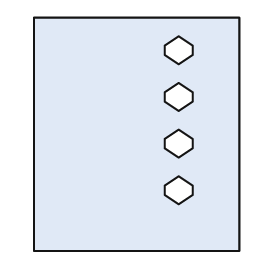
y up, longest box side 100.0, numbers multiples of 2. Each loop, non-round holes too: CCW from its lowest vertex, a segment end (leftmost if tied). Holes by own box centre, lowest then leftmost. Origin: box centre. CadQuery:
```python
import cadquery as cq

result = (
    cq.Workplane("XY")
    .moveTo(-44.0, -50.0)
    .lineTo(44.0, -50.0)
    .lineTo(44.0, 50.0)
    .lineTo(-44.0, 50.0)
    .close()
    .moveTo(18.0, -30.0)
    .lineTo(24.0, -26.0)
    .lineTo(24.0, -22.0)
    .lineTo(18.0, -18.0)
    .lineTo(12.0, -22.0)
    .lineTo(12.0, -26.0)
    .close()
    .moveTo(18.0, -10.0)
    .lineTo(24.0, -6.0)
    .lineTo(24.0, -2.0)
    .lineTo(18.0, 2.0)
    .lineTo(12.0, -2.0)
    .lineTo(12.0, -6.0)
    .close()
    .moveTo(18.0, 10.0)
    .lineTo(24.0, 14.0)
    .lineTo(24.0, 18.0)
    .lineTo(18.0, 22.0)
    .lineTo(12.0, 18.0)
    .lineTo(12.0, 14.0)
    .close()
    .moveTo(18.0, 30.0)
    .lineTo(24.0, 34.0)
    .lineTo(24.0, 38.0)
    .lineTo(18.0, 42.0)
    .lineTo(12.0, 38.0)
    .lineTo(12.0, 34.0)
    .close()
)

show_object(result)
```